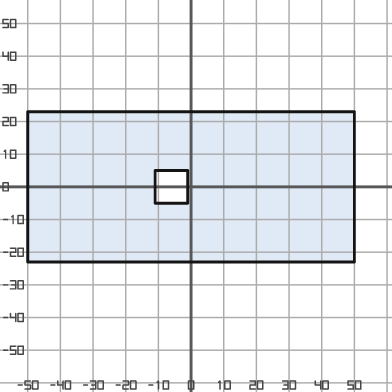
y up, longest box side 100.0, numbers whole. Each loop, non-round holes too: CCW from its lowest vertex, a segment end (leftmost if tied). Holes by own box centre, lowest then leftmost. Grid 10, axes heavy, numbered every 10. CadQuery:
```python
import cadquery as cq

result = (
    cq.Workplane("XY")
    .moveTo(-50.0, -23.0)
    .lineTo(50.0, -23.0)
    .lineTo(50.0, 23.0)
    .lineTo(-50.0, 23.0)
    .close()
    .moveTo(-11.0, -5.0)
    .lineTo(-1.0, -5.0)
    .lineTo(-1.0, 5.0)
    .lineTo(-11.0, 5.0)
    .close()
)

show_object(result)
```